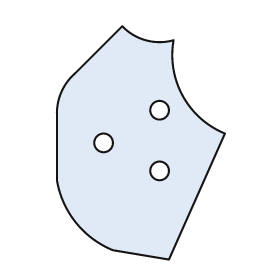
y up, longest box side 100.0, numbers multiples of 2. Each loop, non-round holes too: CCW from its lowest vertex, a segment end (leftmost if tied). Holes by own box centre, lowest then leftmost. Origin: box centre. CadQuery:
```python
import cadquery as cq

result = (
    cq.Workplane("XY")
    .moveTo(12.0, -50.0)
    .lineTo(36.0, 4.0)
    .threePointArc((18.0, 20.0), (14.0, 44.0))
    .threePointArc((2.0, 44.0), (-8.0, 50.0))
    .lineTo(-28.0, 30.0)
    .threePointArc((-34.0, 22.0), (-36.0, 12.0))
    .lineTo(-36.0, -16.0)
    .threePointArc((-28.0, -34.0), (-12.0, -46.0))
    .close()
    .moveTo(8.0, -12.0)
    .circle(4.0)
    .moveTo(-16.0, 0.0)
    .circle(4.0)
    .moveTo(8.0, 14.0)
    .circle(4.0)
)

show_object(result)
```